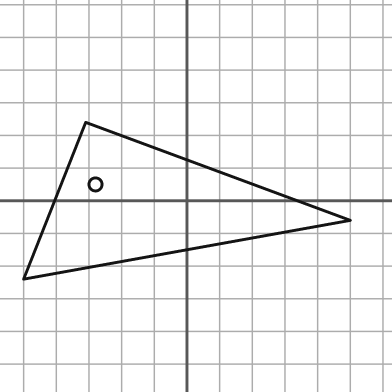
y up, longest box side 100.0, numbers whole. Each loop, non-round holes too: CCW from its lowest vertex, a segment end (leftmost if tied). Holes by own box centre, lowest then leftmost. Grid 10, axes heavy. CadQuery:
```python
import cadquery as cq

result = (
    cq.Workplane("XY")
    .moveTo(-50.0, -24.0)
    .lineTo(50.0, -6.0)
    .lineTo(-31.0, 24.0)
    .close()
    .moveTo(-28.0, 5.0)
    .circle(2.0)
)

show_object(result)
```